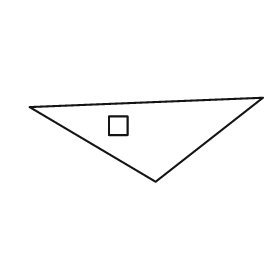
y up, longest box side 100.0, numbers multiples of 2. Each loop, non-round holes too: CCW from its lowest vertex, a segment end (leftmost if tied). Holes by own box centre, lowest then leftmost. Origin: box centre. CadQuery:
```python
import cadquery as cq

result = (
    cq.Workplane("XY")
    .moveTo(4.0, -18.0)
    .lineTo(50.0, 18.0)
    .lineTo(-50.0, 14.0)
    .close()
    .moveTo(-16.0, 2.0)
    .lineTo(-8.0, 2.0)
    .lineTo(-8.0, 10.0)
    .lineTo(-16.0, 10.0)
    .close()
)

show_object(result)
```